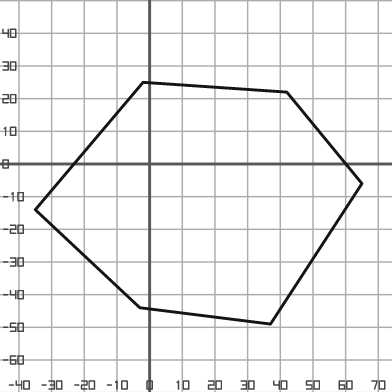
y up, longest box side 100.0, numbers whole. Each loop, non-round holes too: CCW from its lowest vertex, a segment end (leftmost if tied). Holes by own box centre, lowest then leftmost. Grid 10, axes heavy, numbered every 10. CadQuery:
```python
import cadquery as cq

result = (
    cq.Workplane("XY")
    .moveTo(37.0, -49.0)
    .lineTo(65.0, -6.0)
    .lineTo(42.0, 22.0)
    .lineTo(-2.0, 25.0)
    .lineTo(-35.0, -14.0)
    .lineTo(-3.0, -44.0)
    .close()
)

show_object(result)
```